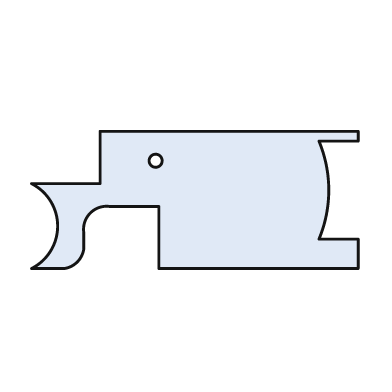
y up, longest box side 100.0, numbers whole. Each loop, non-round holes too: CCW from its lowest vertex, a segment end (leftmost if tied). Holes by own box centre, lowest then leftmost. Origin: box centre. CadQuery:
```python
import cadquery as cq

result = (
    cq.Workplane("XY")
    .moveTo(-50.0, -21.0)
    .lineTo(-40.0, -21.0)
    .threePointArc((-36.0, -19.0), (-34.0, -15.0))
    .lineTo(-34.0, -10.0)
    .threePointArc((-32.0, -4.0), (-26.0, -2.0))
    .lineTo(-11.0, -2.0)
    .lineTo(-11.0, -21.0)
    .lineTo(50.0, -21.0)
    .lineTo(50.0, -12.0)
    .lineTo(38.0, -12.0)
    .threePointArc((41.0, 3.0), (38.0, 18.0))
    .lineTo(50.0, 18.0)
    .lineTo(50.0, 21.0)
    .lineTo(-29.0, 21.0)
    .lineTo(-29.0, 5.0)
    .lineTo(-50.0, 5.0)
    .threePointArc((-42.0, -8.0), (-50.0, -21.0))
    .close()
    .moveTo(-12.0, 12.0)
    .circle(2.0)
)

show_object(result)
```